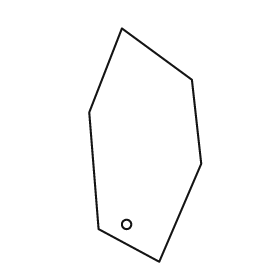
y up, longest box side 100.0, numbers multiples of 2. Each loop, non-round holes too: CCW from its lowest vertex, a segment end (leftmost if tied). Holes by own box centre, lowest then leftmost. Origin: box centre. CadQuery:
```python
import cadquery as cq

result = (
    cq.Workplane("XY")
    .moveTo(6.0, -50.0)
    .lineTo(24.0, -8.0)
    .lineTo(20.0, 28.0)
    .lineTo(-10.0, 50.0)
    .lineTo(-24.0, 14.0)
    .lineTo(-20.0, -36.0)
    .close()
    .moveTo(-8.0, -34.0)
    .circle(2.0)
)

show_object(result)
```